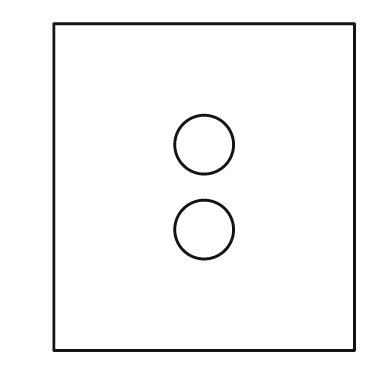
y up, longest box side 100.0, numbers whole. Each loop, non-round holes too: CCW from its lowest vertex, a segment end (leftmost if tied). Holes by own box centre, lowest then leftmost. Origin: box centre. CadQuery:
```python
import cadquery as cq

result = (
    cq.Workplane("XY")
    .moveTo(-46.0, -50.0)
    .lineTo(46.0, -50.0)
    .lineTo(46.0, 50.0)
    .lineTo(-46.0, 50.0)
    .close()
    .moveTo(0.0, -13.0)
    .circle(9.0)
    .moveTo(0.0, 13.0)
    .circle(9.0)
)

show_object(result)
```